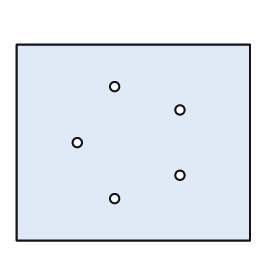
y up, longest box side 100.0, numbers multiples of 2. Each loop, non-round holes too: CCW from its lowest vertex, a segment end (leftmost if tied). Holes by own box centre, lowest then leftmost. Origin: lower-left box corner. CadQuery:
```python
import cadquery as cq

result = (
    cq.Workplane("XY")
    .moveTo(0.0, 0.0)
    .lineTo(100.0, 0.0)
    .lineTo(100.0, 84.0)
    .lineTo(0.0, 84.0)
    .close()
    .moveTo(42.0, 18.0)
    .circle(2.0)
    .moveTo(70.0, 28.0)
    .circle(2.0)
    .moveTo(26.0, 42.0)
    .circle(2.0)
    .moveTo(70.0, 56.0)
    .circle(2.0)
    .moveTo(42.0, 66.0)
    .circle(2.0)
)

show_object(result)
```